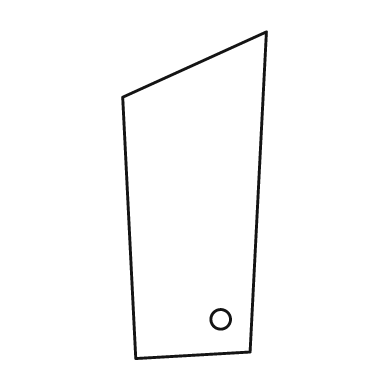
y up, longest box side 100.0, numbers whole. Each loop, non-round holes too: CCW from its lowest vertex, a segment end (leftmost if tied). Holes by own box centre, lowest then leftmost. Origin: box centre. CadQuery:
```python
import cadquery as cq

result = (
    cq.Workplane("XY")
    .moveTo(-18.0, -50.0)
    .lineTo(17.0, -48.0)
    .lineTo(22.0, 50.0)
    .lineTo(-22.0, 30.0)
    .close()
    .moveTo(8.0, -38.0)
    .circle(3.0)
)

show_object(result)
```